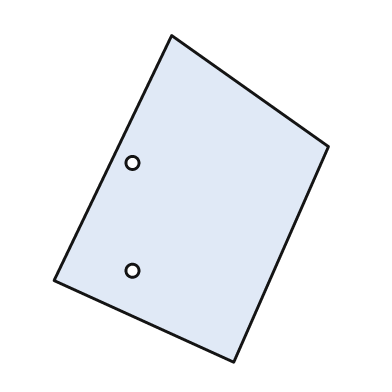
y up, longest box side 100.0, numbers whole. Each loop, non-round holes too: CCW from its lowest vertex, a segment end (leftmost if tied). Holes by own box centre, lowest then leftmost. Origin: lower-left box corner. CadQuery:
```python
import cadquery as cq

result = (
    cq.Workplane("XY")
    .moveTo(55.0, 0.0)
    .lineTo(84.0, 66.0)
    .lineTo(36.0, 100.0)
    .lineTo(0.0, 25.0)
    .close()
    .moveTo(24.0, 28.0)
    .circle(2.0)
    .moveTo(24.0, 61.0)
    .circle(2.0)
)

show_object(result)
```